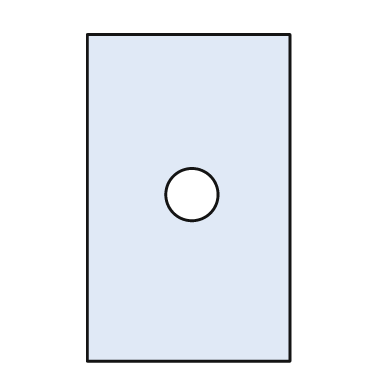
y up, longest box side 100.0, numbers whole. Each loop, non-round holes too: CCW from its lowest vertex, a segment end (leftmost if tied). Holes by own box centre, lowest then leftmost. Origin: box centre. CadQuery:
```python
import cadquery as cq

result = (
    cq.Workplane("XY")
    .moveTo(-31.0, -50.0)
    .lineTo(31.0, -50.0)
    .lineTo(31.0, 50.0)
    .lineTo(-31.0, 50.0)
    .close()
    .moveTo(1.0, 1.0)
    .circle(8.0)
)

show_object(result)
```